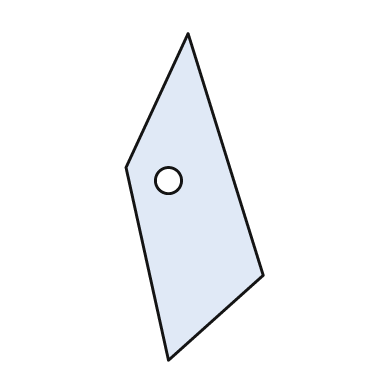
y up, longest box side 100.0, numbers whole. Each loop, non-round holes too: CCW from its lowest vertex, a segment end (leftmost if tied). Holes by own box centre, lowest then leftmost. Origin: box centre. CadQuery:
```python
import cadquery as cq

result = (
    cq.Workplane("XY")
    .moveTo(-8.0, -50.0)
    .lineTo(21.0, -24.0)
    .lineTo(-2.0, 50.0)
    .lineTo(-21.0, 9.0)
    .close()
    .moveTo(-8.0, 5.0)
    .circle(4.0)
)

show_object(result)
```